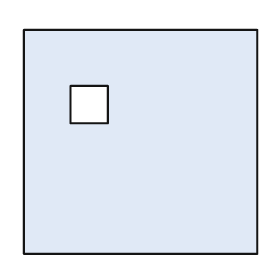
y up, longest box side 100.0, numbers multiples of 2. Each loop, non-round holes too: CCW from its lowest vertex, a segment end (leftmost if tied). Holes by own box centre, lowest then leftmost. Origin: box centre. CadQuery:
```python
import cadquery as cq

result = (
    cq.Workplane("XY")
    .moveTo(-50.0, -48.0)
    .lineTo(50.0, -48.0)
    .lineTo(50.0, 48.0)
    .lineTo(-50.0, 48.0)
    .close()
    .moveTo(-30.0, 8.0)
    .lineTo(-14.0, 8.0)
    .lineTo(-14.0, 24.0)
    .lineTo(-30.0, 24.0)
    .close()
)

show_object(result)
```